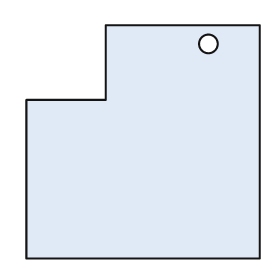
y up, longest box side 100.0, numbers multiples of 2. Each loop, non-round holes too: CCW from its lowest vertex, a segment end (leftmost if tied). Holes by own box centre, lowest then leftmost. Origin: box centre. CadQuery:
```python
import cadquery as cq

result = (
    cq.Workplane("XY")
    .moveTo(-50.0, -50.0)
    .lineTo(50.0, -50.0)
    .lineTo(50.0, 50.0)
    .lineTo(-16.0, 50.0)
    .lineTo(-16.0, 18.0)
    .lineTo(-50.0, 18.0)
    .close()
    .moveTo(28.0, 42.0)
    .circle(4.0)
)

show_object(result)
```